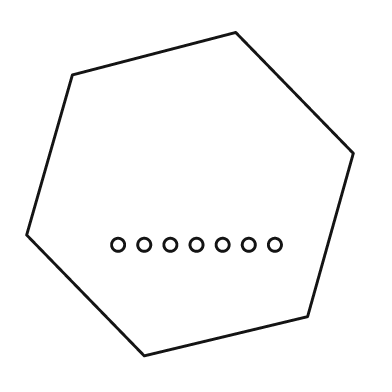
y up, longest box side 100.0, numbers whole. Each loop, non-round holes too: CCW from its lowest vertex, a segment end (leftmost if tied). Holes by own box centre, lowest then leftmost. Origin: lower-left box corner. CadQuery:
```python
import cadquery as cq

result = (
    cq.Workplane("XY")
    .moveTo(36.0, 0.0)
    .lineTo(86.0, 12.0)
    .lineTo(100.0, 62.0)
    .lineTo(64.0, 99.0)
    .lineTo(14.0, 86.0)
    .lineTo(0.0, 37.0)
    .close()
    .moveTo(28.0, 34.0)
    .circle(2.0)
    .moveTo(36.0, 34.0)
    .circle(2.0)
    .moveTo(44.0, 34.0)
    .circle(2.0)
    .moveTo(52.0, 34.0)
    .circle(2.0)
    .moveTo(60.0, 34.0)
    .circle(2.0)
    .moveTo(68.0, 34.0)
    .circle(2.0)
    .moveTo(76.0, 34.0)
    .circle(2.0)
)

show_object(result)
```